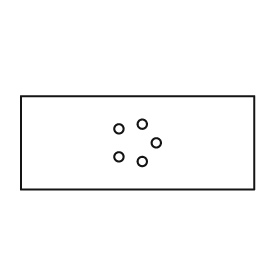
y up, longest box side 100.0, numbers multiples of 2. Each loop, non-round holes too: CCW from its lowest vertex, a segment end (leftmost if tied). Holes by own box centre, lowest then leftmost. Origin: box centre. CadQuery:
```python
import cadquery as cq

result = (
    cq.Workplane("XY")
    .moveTo(-50.0, -20.0)
    .lineTo(50.0, -20.0)
    .lineTo(50.0, 20.0)
    .lineTo(-50.0, 20.0)
    .close()
    .moveTo(2.0, -8.0)
    .circle(2.0)
    .moveTo(-8.0, -6.0)
    .circle(2.0)
    .moveTo(8.0, 0.0)
    .circle(2.0)
    .moveTo(-8.0, 6.0)
    .circle(2.0)
    .moveTo(2.0, 8.0)
    .circle(2.0)
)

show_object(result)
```